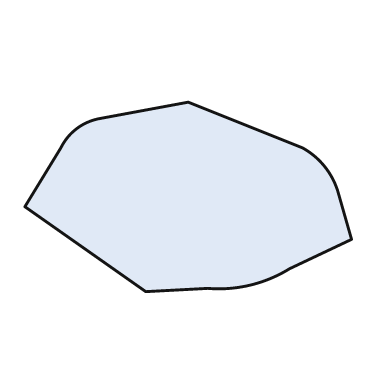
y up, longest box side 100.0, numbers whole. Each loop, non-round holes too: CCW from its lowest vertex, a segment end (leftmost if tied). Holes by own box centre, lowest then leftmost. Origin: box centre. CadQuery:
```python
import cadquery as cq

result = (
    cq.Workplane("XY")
    .moveTo(-13.0, -29.0)
    .lineTo(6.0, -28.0)
    .threePointArc((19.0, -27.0), (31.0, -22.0))
    .lineTo(50.0, -13.0)
    .lineTo(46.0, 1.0)
    .threePointArc((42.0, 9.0), (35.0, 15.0))
    .lineTo(0.0, 29.0)
    .lineTo(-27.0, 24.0)
    .threePointArc((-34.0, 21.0), (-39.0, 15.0))
    .lineTo(-50.0, -3.0)
    .close()
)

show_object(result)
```